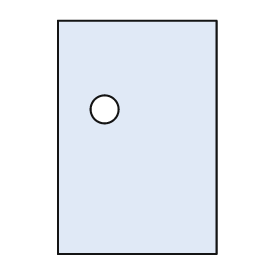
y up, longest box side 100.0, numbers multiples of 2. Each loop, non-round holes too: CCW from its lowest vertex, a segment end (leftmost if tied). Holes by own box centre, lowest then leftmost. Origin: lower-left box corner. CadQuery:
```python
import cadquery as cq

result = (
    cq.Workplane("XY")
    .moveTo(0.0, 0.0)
    .lineTo(68.0, 0.0)
    .lineTo(68.0, 100.0)
    .lineTo(0.0, 100.0)
    .close()
    .moveTo(20.0, 62.0)
    .circle(6.0)
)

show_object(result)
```